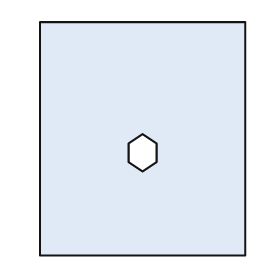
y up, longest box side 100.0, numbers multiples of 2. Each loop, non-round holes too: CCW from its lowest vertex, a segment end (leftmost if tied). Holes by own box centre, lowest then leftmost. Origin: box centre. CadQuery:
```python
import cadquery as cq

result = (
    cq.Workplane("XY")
    .moveTo(-44.0, -50.0)
    .lineTo(44.0, -50.0)
    .lineTo(44.0, 50.0)
    .lineTo(-44.0, 50.0)
    .close()
    .moveTo(0.0, -14.0)
    .lineTo(6.0, -10.0)
    .lineTo(6.0, -2.0)
    .lineTo(0.0, 2.0)
    .lineTo(-6.0, -2.0)
    .lineTo(-6.0, -10.0)
    .close()
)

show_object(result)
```